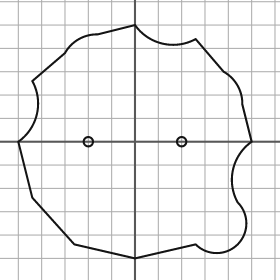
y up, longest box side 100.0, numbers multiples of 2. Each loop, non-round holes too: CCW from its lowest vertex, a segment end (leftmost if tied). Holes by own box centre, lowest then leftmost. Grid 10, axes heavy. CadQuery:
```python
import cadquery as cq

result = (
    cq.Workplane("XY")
    .moveTo(0.0, -50.0)
    .lineTo(26.0, -44.0)
    .threePointArc((44.0, -44.0), (44.0, -26.0))
    .threePointArc((42.0, -12.0), (50.0, 0.0))
    .lineTo(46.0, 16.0)
    .threePointArc((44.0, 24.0), (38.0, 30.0))
    .lineTo(26.0, 44.0)
    .threePointArc((12.0, 42.0), (0.0, 50.0))
    .lineTo(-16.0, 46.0)
    .threePointArc((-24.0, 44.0), (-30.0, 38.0))
    .lineTo(-44.0, 26.0)
    .threePointArc((-42.0, 12.0), (-50.0, 0.0))
    .lineTo(-44.0, -24.0)
    .lineTo(-26.0, -44.0)
    .close()
    .moveTo(-20.0, 0.0)
    .circle(2.0)
    .moveTo(20.0, 0.0)
    .circle(2.0)
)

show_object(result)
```